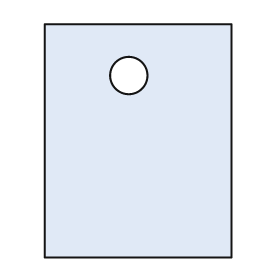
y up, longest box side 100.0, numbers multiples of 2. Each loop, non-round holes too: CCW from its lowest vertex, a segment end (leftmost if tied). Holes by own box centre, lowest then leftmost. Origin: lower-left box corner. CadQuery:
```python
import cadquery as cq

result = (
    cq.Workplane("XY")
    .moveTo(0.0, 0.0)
    .lineTo(80.0, 0.0)
    .lineTo(80.0, 100.0)
    .lineTo(0.0, 100.0)
    .close()
    .moveTo(36.0, 78.0)
    .circle(8.0)
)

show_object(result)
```